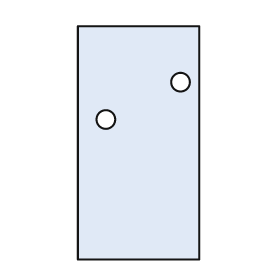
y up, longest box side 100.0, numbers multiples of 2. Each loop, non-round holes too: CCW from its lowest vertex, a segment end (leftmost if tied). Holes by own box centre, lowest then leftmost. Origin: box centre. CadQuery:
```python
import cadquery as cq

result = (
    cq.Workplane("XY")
    .moveTo(-26.0, -50.0)
    .lineTo(26.0, -50.0)
    .lineTo(26.0, 50.0)
    .lineTo(-26.0, 50.0)
    .close()
    .moveTo(-14.0, 10.0)
    .circle(4.0)
    .moveTo(18.0, 26.0)
    .circle(4.0)
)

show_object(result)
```